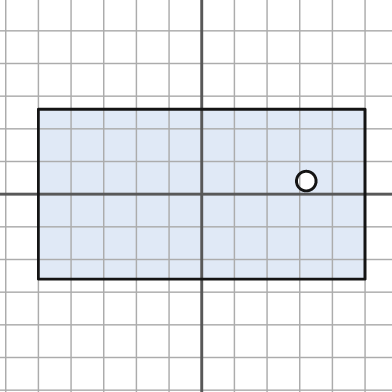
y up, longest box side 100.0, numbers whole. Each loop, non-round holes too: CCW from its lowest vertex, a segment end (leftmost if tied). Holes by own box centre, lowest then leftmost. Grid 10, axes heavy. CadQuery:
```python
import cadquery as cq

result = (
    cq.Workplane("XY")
    .moveTo(-50.0, -26.0)
    .lineTo(50.0, -26.0)
    .lineTo(50.0, 26.0)
    .lineTo(-50.0, 26.0)
    .close()
    .moveTo(32.0, 4.0)
    .circle(3.0)
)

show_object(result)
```